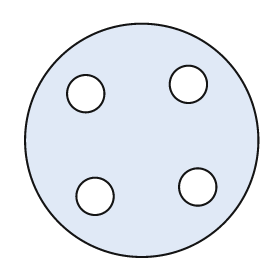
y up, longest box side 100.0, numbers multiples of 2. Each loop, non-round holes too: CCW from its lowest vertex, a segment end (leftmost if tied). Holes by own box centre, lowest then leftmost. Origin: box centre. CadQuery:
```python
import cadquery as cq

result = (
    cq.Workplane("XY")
    .moveTo(0.0, 0.0)
    .circle(50.0)
    .moveTo(-20.0, -24.0)
    .circle(8.0)
    .moveTo(24.0, -20.0)
    .circle(8.0)
    .moveTo(-24.0, 20.0)
    .circle(8.0)
    .moveTo(20.0, 24.0)
    .circle(8.0)
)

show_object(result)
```